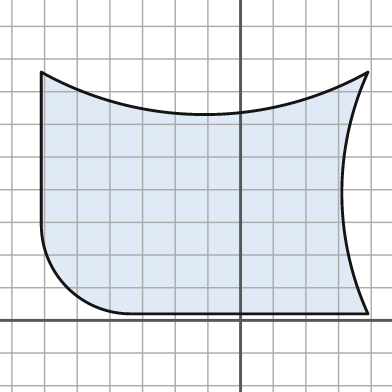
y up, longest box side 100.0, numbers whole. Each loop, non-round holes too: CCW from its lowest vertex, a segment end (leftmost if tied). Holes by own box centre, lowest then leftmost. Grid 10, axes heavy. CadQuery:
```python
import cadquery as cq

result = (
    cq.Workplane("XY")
    .moveTo(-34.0, 2.0)
    .lineTo(39.0, 2.0)
    .threePointArc((31.0, 39.0), (39.0, 76.0))
    .threePointArc((-11.0, 63.0), (-61.0, 76.0))
    .lineTo(-61.0, 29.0)
    .threePointArc((-53.0, 10.0), (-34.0, 2.0))
    .close()
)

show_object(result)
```